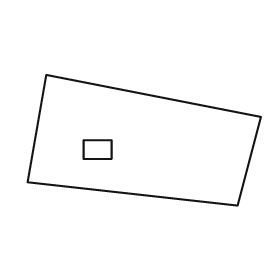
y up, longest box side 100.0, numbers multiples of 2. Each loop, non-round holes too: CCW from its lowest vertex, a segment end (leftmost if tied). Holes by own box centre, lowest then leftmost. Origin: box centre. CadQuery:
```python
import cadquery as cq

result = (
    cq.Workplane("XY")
    .moveTo(40.0, -28.0)
    .lineTo(50.0, 10.0)
    .lineTo(-42.0, 28.0)
    .lineTo(-50.0, -18.0)
    .close()
    .moveTo(-26.0, -8.0)
    .lineTo(-14.0, -8.0)
    .lineTo(-14.0, 0.0)
    .lineTo(-26.0, 0.0)
    .close()
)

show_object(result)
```